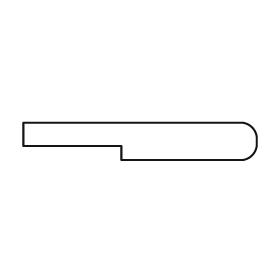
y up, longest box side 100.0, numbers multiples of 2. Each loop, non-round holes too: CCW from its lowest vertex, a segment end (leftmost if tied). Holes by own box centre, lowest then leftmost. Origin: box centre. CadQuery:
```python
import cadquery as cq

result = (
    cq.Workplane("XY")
    .moveTo(-8.0, -8.0)
    .lineTo(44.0, -8.0)
    .threePointArc((48.0, -6.0), (50.0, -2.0))
    .lineTo(50.0, 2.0)
    .threePointArc((48.0, 6.0), (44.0, 8.0))
    .lineTo(-50.0, 8.0)
    .lineTo(-50.0, -2.0)
    .lineTo(-8.0, -2.0)
    .close()
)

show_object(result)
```